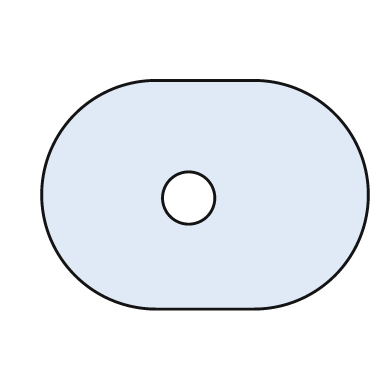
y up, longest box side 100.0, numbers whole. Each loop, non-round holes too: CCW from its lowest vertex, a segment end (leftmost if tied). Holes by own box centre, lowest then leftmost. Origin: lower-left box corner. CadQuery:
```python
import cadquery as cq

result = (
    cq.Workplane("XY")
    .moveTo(35.0, 0.0)
    .lineTo(65.0, 0.0)
    .threePointArc((100.0, 35.0), (65.0, 70.0))
    .lineTo(35.0, 70.0)
    .threePointArc((0.0, 35.0), (35.0, 0.0))
    .close()
    .moveTo(45.0, 34.0)
    .circle(8.0)
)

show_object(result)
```